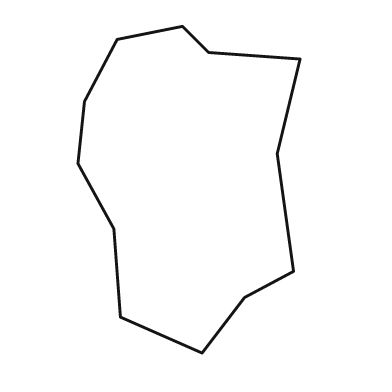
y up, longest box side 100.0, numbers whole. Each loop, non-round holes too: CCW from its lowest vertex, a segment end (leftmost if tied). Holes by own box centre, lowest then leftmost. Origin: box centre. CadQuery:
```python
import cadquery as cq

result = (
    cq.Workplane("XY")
    .moveTo(4.0, -50.0)
    .lineTo(17.0, -33.0)
    .lineTo(32.0, -25.0)
    .lineTo(27.0, 11.0)
    .lineTo(34.0, 40.0)
    .lineTo(6.0, 42.0)
    .lineTo(-2.0, 50.0)
    .lineTo(-22.0, 46.0)
    .lineTo(-32.0, 27.0)
    .lineTo(-34.0, 8.0)
    .lineTo(-23.0, -12.0)
    .lineTo(-21.0, -39.0)
    .close()
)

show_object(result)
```